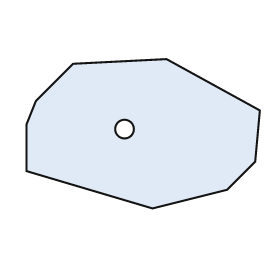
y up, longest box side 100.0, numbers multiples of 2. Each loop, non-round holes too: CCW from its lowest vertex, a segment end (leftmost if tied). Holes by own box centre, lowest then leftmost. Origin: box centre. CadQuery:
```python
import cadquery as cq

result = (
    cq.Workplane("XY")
    .moveTo(4.0, -32.0)
    .lineTo(36.0, -24.0)
    .lineTo(48.0, -12.0)
    .lineTo(50.0, 10.0)
    .lineTo(10.0, 32.0)
    .lineTo(-30.0, 30.0)
    .lineTo(-46.0, 14.0)
    .lineTo(-50.0, 4.0)
    .lineTo(-50.0, -16.0)
    .close()
    .moveTo(-8.0, 2.0)
    .circle(4.0)
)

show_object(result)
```